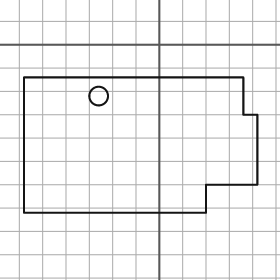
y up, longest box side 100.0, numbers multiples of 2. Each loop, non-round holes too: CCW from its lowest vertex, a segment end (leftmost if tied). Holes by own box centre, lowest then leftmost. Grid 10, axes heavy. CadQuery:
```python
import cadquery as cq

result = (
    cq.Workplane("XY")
    .moveTo(-58.0, -72.0)
    .lineTo(20.0, -72.0)
    .lineTo(20.0, -60.0)
    .lineTo(42.0, -60.0)
    .lineTo(42.0, -30.0)
    .lineTo(36.0, -30.0)
    .lineTo(36.0, -14.0)
    .lineTo(-58.0, -14.0)
    .close()
    .moveTo(-26.0, -22.0)
    .circle(4.0)
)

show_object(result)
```